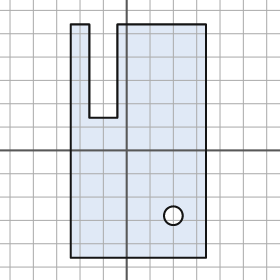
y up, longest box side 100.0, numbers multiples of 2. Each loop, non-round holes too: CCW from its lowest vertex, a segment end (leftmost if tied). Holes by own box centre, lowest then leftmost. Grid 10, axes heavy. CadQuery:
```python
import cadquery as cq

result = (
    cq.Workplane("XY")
    .moveTo(-24.0, -46.0)
    .lineTo(34.0, -46.0)
    .lineTo(34.0, 54.0)
    .lineTo(-4.0, 54.0)
    .lineTo(-4.0, 14.0)
    .lineTo(-16.0, 14.0)
    .lineTo(-16.0, 54.0)
    .lineTo(-24.0, 54.0)
    .close()
    .moveTo(20.0, -28.0)
    .circle(4.0)
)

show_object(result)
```